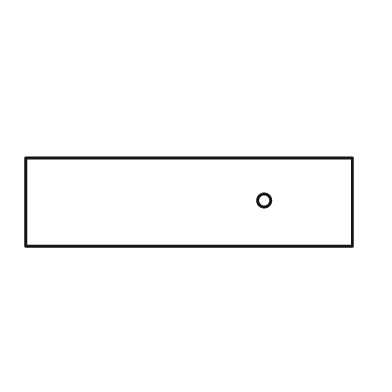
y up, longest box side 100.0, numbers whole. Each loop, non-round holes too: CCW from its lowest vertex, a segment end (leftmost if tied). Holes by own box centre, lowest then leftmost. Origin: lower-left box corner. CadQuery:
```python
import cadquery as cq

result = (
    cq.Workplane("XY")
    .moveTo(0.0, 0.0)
    .lineTo(100.0, 0.0)
    .lineTo(100.0, 27.0)
    .lineTo(0.0, 27.0)
    .close()
    .moveTo(73.0, 14.0)
    .circle(2.0)
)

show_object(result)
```